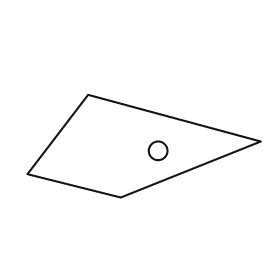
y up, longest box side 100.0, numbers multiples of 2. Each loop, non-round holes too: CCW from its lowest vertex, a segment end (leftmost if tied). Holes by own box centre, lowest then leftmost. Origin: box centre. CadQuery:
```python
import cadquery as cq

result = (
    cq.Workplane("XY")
    .moveTo(-10.0, -22.0)
    .lineTo(50.0, 2.0)
    .lineTo(-24.0, 22.0)
    .lineTo(-50.0, -12.0)
    .close()
    .moveTo(6.0, -2.0)
    .circle(4.0)
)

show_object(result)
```